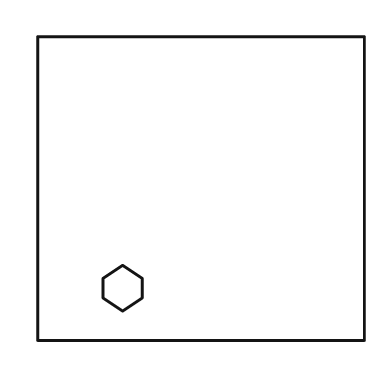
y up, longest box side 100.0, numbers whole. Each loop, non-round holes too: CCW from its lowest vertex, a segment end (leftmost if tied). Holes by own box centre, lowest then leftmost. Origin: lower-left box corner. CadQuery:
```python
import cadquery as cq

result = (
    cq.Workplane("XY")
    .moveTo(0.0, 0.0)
    .lineTo(100.0, 0.0)
    .lineTo(100.0, 93.0)
    .lineTo(0.0, 93.0)
    .close()
    .moveTo(26.0, 9.0)
    .lineTo(32.0, 13.0)
    .lineTo(32.0, 19.0)
    .lineTo(26.0, 23.0)
    .lineTo(20.0, 19.0)
    .lineTo(20.0, 13.0)
    .close()
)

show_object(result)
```